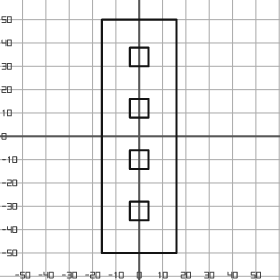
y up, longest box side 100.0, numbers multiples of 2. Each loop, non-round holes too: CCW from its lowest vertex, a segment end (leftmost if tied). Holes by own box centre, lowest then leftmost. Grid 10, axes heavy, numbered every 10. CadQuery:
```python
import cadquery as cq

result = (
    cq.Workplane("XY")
    .moveTo(-16.0, -50.0)
    .lineTo(16.0, -50.0)
    .lineTo(16.0, 50.0)
    .lineTo(-16.0, 50.0)
    .close()
    .moveTo(-4.0, -36.0)
    .lineTo(4.0, -36.0)
    .lineTo(4.0, -28.0)
    .lineTo(-4.0, -28.0)
    .close()
    .moveTo(-4.0, -14.0)
    .lineTo(4.0, -14.0)
    .lineTo(4.0, -6.0)
    .lineTo(-4.0, -6.0)
    .close()
    .moveTo(-4.0, 8.0)
    .lineTo(4.0, 8.0)
    .lineTo(4.0, 16.0)
    .lineTo(-4.0, 16.0)
    .close()
    .moveTo(-4.0, 30.0)
    .lineTo(4.0, 30.0)
    .lineTo(4.0, 38.0)
    .lineTo(-4.0, 38.0)
    .close()
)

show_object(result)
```